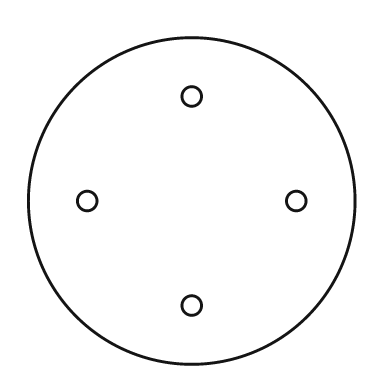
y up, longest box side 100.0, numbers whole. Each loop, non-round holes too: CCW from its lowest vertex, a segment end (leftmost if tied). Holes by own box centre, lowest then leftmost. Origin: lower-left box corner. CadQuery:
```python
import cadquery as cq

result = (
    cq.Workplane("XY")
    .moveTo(50.0, 50.0)
    .circle(50.0)
    .moveTo(50.0, 18.0)
    .circle(3.0)
    .moveTo(18.0, 50.0)
    .circle(3.0)
    .moveTo(82.0, 50.0)
    .circle(3.0)
    .moveTo(50.0, 82.0)
    .circle(3.0)
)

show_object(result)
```